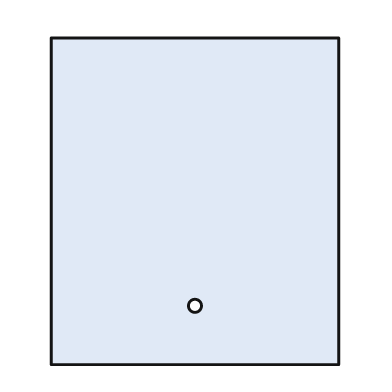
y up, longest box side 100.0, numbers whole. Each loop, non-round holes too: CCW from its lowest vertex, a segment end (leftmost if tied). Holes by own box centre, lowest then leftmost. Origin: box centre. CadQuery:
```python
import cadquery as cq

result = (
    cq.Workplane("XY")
    .moveTo(-44.0, -50.0)
    .lineTo(44.0, -50.0)
    .lineTo(44.0, 50.0)
    .lineTo(-44.0, 50.0)
    .close()
    .moveTo(0.0, -32.0)
    .circle(2.0)
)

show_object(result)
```